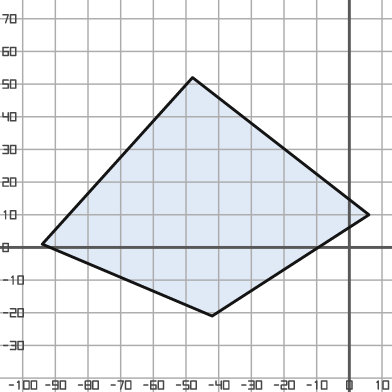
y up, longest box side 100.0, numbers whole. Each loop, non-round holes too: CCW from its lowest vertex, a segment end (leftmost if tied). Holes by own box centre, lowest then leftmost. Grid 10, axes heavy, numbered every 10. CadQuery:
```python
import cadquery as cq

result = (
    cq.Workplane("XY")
    .moveTo(-42.0, -21.0)
    .lineTo(6.0, 10.0)
    .lineTo(-48.0, 52.0)
    .lineTo(-94.0, 1.0)
    .close()
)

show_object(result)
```